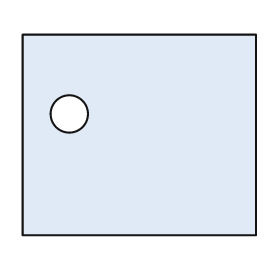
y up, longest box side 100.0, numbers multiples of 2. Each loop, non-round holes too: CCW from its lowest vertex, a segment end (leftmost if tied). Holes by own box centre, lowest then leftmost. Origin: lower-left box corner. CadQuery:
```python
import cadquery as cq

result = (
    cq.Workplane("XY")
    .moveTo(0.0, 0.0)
    .lineTo(100.0, 0.0)
    .lineTo(100.0, 86.0)
    .lineTo(0.0, 86.0)
    .close()
    .moveTo(20.0, 52.0)
    .circle(8.0)
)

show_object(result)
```